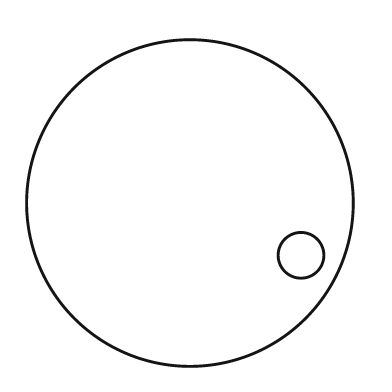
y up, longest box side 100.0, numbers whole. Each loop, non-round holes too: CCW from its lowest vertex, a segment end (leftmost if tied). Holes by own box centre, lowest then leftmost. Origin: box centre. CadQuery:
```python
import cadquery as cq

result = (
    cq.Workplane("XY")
    .moveTo(0.0, 0.0)
    .circle(50.0)
    .moveTo(34.0, -16.0)
    .circle(7.0)
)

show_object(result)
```